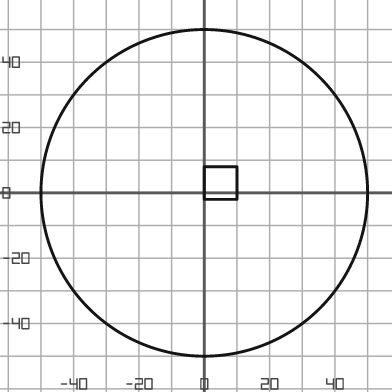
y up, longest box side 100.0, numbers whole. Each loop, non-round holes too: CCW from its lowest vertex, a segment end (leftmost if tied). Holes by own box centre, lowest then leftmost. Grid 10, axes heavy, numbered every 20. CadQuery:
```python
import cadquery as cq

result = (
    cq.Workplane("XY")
    .moveTo(0.0, 0.0)
    .circle(50.0)
    .moveTo(0.0, -2.0)
    .lineTo(10.0, -2.0)
    .lineTo(10.0, 8.0)
    .lineTo(0.0, 8.0)
    .close()
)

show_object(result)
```